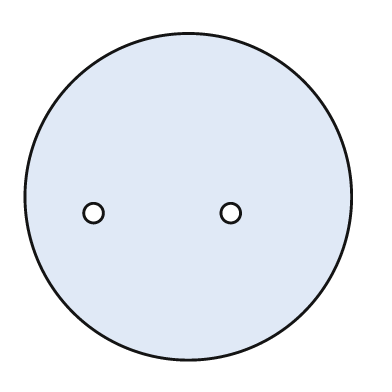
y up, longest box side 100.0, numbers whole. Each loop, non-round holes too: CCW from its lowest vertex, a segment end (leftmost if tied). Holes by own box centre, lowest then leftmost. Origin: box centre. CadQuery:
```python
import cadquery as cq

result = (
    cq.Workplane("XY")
    .moveTo(0.0, 0.0)
    .circle(50.0)
    .moveTo(-29.0, -5.0)
    .circle(3.0)
    .moveTo(13.0, -5.0)
    .circle(3.0)
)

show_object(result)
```